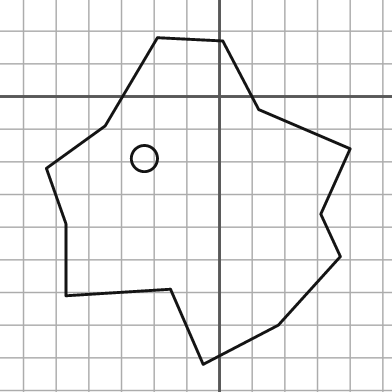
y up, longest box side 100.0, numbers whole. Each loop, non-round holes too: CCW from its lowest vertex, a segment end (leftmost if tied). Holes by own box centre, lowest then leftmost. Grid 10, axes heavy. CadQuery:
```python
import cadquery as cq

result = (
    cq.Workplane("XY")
    .moveTo(-5.0, -82.0)
    .lineTo(18.0, -70.0)
    .lineTo(37.0, -49.0)
    .lineTo(31.0, -36.0)
    .lineTo(40.0, -16.0)
    .lineTo(12.0, -4.0)
    .lineTo(1.0, 17.0)
    .lineTo(-19.0, 18.0)
    .lineTo(-35.0, -9.0)
    .lineTo(-53.0, -22.0)
    .lineTo(-47.0, -39.0)
    .lineTo(-47.0, -61.0)
    .lineTo(-15.0, -59.0)
    .close()
    .moveTo(-23.0, -19.0)
    .circle(4.0)
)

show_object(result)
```